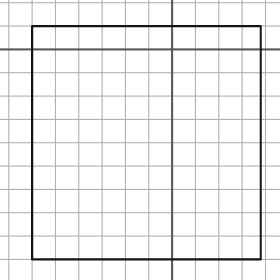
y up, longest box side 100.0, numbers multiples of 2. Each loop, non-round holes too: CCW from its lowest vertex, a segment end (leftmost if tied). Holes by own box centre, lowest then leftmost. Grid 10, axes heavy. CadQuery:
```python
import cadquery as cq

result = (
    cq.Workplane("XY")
    .moveTo(-60.0, -90.0)
    .lineTo(38.0, -90.0)
    .lineTo(38.0, 10.0)
    .lineTo(-60.0, 10.0)
    .close()
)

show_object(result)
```